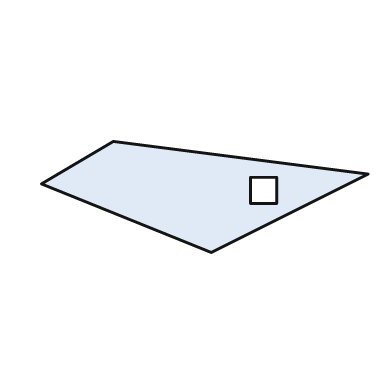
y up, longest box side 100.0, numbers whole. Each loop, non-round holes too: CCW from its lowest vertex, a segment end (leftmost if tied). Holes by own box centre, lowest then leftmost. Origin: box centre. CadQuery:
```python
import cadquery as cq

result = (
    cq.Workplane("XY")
    .moveTo(2.0, -17.0)
    .lineTo(50.0, 7.0)
    .lineTo(-28.0, 17.0)
    .lineTo(-50.0, 4.0)
    .close()
    .moveTo(14.0, -2.0)
    .lineTo(22.0, -2.0)
    .lineTo(22.0, 6.0)
    .lineTo(14.0, 6.0)
    .close()
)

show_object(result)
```